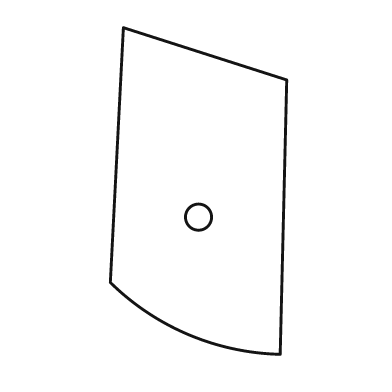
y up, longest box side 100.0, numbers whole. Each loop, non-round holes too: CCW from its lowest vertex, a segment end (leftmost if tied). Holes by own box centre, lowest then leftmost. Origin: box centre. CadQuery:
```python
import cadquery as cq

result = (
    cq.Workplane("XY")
    .moveTo(25.0, -50.0)
    .lineTo(27.0, 34.0)
    .lineTo(-23.0, 50.0)
    .lineTo(-27.0, -28.0)
    .threePointArc((-3.0, -44.0), (25.0, -50.0))
    .close()
    .moveTo(0.0, -8.0)
    .circle(4.0)
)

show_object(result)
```